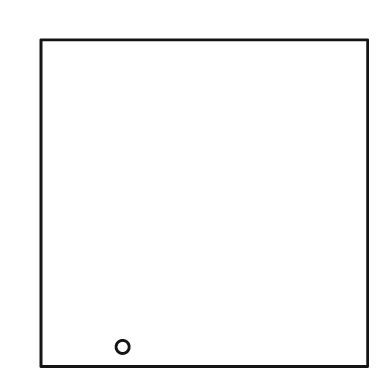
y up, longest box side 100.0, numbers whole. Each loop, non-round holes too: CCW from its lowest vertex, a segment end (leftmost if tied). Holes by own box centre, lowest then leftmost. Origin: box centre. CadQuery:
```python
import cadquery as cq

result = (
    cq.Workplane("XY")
    .moveTo(-50.0, -50.0)
    .lineTo(50.0, -50.0)
    .lineTo(50.0, 50.0)
    .lineTo(-50.0, 50.0)
    .close()
    .moveTo(-25.0, -44.0)
    .circle(2.0)
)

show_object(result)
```